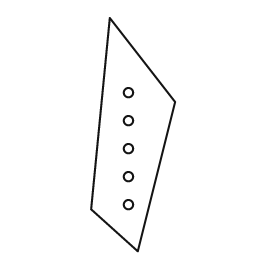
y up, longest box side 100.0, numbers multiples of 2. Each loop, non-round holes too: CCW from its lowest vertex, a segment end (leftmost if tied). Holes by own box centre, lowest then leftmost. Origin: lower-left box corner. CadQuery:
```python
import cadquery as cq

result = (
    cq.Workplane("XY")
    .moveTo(20.0, 0.0)
    .lineTo(36.0, 64.0)
    .lineTo(8.0, 100.0)
    .lineTo(0.0, 18.0)
    .close()
    .moveTo(16.0, 20.0)
    .circle(2.0)
    .moveTo(16.0, 32.0)
    .circle(2.0)
    .moveTo(16.0, 44.0)
    .circle(2.0)
    .moveTo(16.0, 56.0)
    .circle(2.0)
    .moveTo(16.0, 68.0)
    .circle(2.0)
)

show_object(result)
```